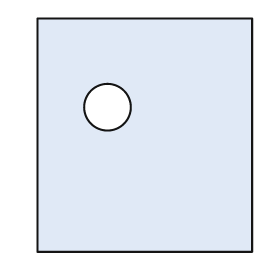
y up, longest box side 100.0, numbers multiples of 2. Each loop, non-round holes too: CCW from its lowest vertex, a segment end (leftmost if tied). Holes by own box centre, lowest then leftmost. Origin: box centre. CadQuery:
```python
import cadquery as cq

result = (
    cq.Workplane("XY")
    .moveTo(-46.0, -50.0)
    .lineTo(46.0, -50.0)
    .lineTo(46.0, 50.0)
    .lineTo(-46.0, 50.0)
    .close()
    .moveTo(-16.0, 12.0)
    .circle(10.0)
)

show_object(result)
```